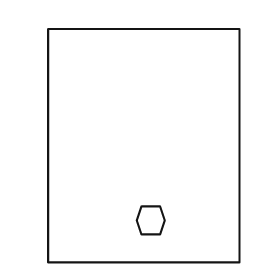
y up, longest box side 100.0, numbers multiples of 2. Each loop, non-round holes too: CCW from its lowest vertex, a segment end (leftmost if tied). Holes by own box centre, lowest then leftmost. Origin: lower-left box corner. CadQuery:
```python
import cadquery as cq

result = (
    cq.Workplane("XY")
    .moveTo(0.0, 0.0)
    .lineTo(82.0, 0.0)
    .lineTo(82.0, 100.0)
    .lineTo(0.0, 100.0)
    .close()
    .moveTo(40.0, 12.0)
    .lineTo(48.0, 12.0)
    .lineTo(50.0, 18.0)
    .lineTo(48.0, 24.0)
    .lineTo(40.0, 24.0)
    .lineTo(38.0, 18.0)
    .close()
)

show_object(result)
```